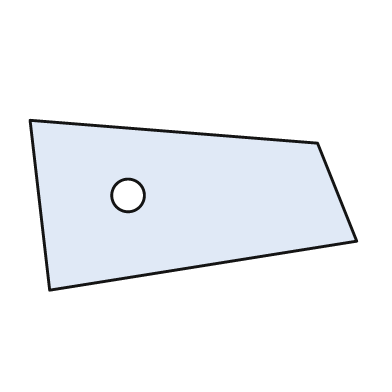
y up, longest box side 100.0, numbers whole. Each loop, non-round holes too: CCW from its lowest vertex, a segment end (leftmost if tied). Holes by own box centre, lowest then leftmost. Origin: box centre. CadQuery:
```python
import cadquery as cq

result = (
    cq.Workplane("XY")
    .moveTo(-44.0, -26.0)
    .lineTo(50.0, -11.0)
    .lineTo(38.0, 19.0)
    .lineTo(-50.0, 26.0)
    .close()
    .moveTo(-20.0, 3.0)
    .circle(5.0)
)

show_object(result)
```